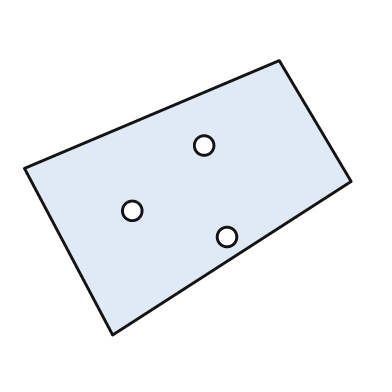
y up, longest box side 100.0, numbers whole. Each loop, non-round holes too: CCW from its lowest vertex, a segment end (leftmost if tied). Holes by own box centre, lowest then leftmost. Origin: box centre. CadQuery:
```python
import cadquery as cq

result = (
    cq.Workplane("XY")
    .moveTo(-23.0, -42.0)
    .lineTo(50.0, 5.0)
    .lineTo(28.0, 42.0)
    .lineTo(-50.0, 9.0)
    .close()
    .moveTo(12.0, -12.0)
    .circle(3.0)
    .moveTo(-17.0, -4.0)
    .circle(3.0)
    .moveTo(5.0, 16.0)
    .circle(3.0)
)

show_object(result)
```